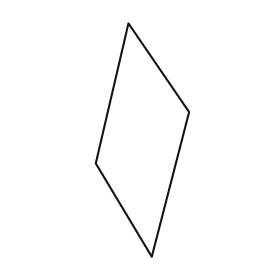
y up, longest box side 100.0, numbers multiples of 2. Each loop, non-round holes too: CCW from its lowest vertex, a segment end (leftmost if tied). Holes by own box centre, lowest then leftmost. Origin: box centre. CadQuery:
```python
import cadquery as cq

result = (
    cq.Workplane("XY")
    .moveTo(4.0, -50.0)
    .lineTo(20.0, 12.0)
    .lineTo(-6.0, 50.0)
    .lineTo(-20.0, -10.0)
    .close()
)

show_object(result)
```